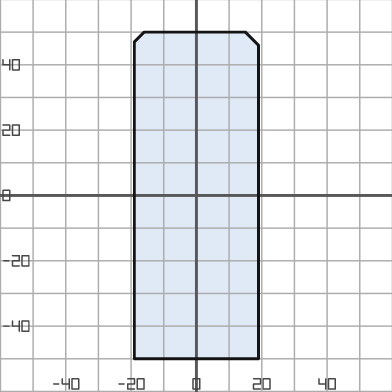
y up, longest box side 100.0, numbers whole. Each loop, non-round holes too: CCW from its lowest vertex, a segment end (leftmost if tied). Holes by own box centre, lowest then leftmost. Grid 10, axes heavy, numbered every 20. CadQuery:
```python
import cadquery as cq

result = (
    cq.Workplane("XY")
    .moveTo(-19.0, -50.0)
    .lineTo(19.0, -50.0)
    .lineTo(19.0, 46.0)
    .lineTo(15.0, 50.0)
    .lineTo(-16.0, 50.0)
    .lineTo(-19.0, 47.0)
    .close()
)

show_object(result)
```